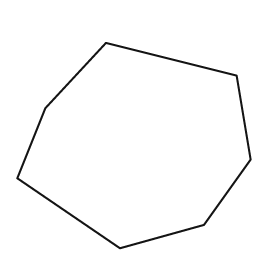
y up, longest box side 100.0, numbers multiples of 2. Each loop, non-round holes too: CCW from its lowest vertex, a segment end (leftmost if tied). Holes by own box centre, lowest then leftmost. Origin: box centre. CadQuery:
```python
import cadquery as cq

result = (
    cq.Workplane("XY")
    .moveTo(-6.0, -44.0)
    .lineTo(30.0, -34.0)
    .lineTo(50.0, -6.0)
    .lineTo(44.0, 30.0)
    .lineTo(-12.0, 44.0)
    .lineTo(-38.0, 16.0)
    .lineTo(-50.0, -14.0)
    .close()
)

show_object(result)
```